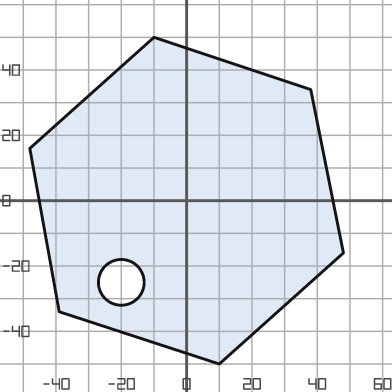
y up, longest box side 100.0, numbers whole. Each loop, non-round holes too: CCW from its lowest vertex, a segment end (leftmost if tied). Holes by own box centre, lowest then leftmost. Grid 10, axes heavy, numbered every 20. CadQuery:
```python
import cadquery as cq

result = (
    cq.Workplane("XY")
    .moveTo(10.0, -50.0)
    .lineTo(48.0, -16.0)
    .lineTo(38.0, 34.0)
    .lineTo(-10.0, 50.0)
    .lineTo(-48.0, 16.0)
    .lineTo(-39.0, -34.0)
    .close()
    .moveTo(-20.0, -25.0)
    .circle(7.0)
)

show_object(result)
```